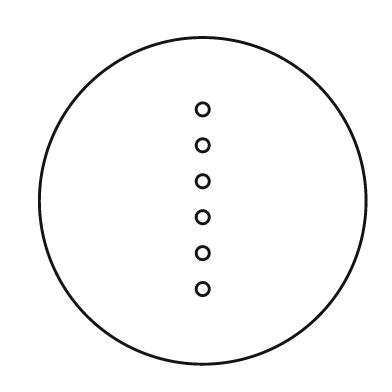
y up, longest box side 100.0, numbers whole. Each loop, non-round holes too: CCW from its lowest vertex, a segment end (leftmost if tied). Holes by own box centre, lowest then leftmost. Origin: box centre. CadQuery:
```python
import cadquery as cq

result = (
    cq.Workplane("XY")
    .moveTo(0.0, 0.0)
    .circle(50.0)
    .moveTo(0.0, -27.0)
    .circle(2.0)
    .moveTo(0.0, -16.0)
    .circle(2.0)
    .moveTo(0.0, -5.0)
    .circle(2.0)
    .moveTo(0.0, 6.0)
    .circle(2.0)
    .moveTo(0.0, 17.0)
    .circle(2.0)
    .moveTo(0.0, 28.0)
    .circle(2.0)
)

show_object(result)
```